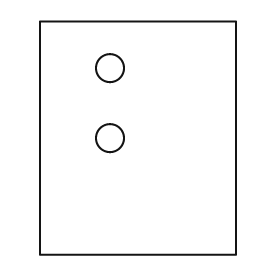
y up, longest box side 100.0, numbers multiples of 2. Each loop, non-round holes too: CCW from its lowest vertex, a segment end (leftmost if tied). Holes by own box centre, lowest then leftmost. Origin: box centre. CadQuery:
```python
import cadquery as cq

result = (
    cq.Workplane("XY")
    .moveTo(-42.0, -50.0)
    .lineTo(42.0, -50.0)
    .lineTo(42.0, 50.0)
    .lineTo(-42.0, 50.0)
    .close()
    .moveTo(-12.0, 0.0)
    .circle(6.0)
    .moveTo(-12.0, 30.0)
    .circle(6.0)
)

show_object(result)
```